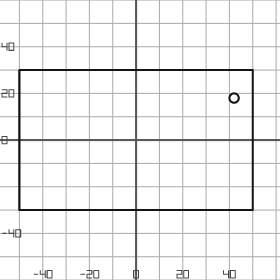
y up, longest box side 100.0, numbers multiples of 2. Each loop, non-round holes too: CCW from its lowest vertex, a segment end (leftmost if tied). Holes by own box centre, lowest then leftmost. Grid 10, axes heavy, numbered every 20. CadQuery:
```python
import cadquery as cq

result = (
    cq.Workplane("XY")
    .moveTo(-50.0, -30.0)
    .lineTo(50.0, -30.0)
    .lineTo(50.0, 30.0)
    .lineTo(-50.0, 30.0)
    .close()
    .moveTo(42.0, 18.0)
    .circle(2.0)
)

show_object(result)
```